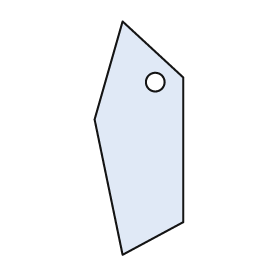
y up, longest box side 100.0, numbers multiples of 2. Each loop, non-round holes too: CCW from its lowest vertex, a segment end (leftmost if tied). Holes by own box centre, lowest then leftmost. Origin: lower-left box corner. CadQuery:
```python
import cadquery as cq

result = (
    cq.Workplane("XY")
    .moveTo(12.0, 0.0)
    .lineTo(38.0, 14.0)
    .lineTo(38.0, 76.0)
    .lineTo(12.0, 100.0)
    .lineTo(0.0, 58.0)
    .close()
    .moveTo(26.0, 74.0)
    .circle(4.0)
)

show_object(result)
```